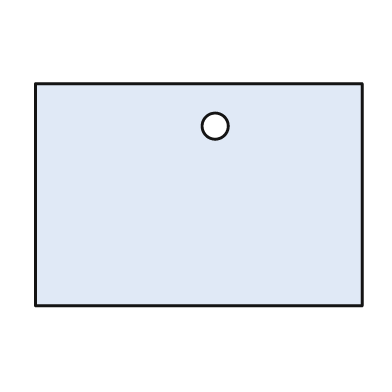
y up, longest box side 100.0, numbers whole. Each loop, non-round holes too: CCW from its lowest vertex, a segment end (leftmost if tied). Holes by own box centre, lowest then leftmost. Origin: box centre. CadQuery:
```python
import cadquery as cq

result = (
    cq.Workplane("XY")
    .moveTo(-50.0, -34.0)
    .lineTo(50.0, -34.0)
    .lineTo(50.0, 34.0)
    .lineTo(-50.0, 34.0)
    .close()
    .moveTo(5.0, 21.0)
    .circle(4.0)
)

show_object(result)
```